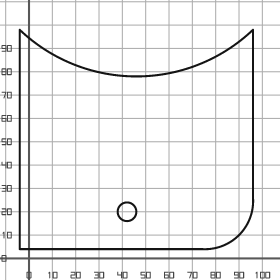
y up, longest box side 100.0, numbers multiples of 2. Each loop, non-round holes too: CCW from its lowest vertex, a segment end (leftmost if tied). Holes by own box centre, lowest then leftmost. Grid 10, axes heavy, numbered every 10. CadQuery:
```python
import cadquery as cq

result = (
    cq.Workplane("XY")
    .moveTo(-4.0, 4.0)
    .lineTo(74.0, 4.0)
    .threePointArc((90.0, 10.0), (96.0, 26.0))
    .lineTo(96.0, 98.0)
    .threePointArc((46.0, 78.0), (-4.0, 98.0))
    .close()
    .moveTo(42.0, 20.0)
    .circle(4.0)
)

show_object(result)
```